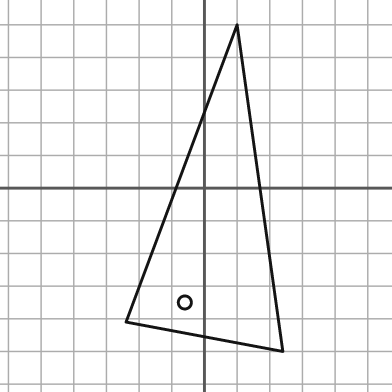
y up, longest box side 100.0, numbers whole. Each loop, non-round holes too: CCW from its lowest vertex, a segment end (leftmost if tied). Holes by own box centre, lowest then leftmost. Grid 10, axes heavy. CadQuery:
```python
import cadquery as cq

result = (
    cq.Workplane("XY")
    .moveTo(24.0, -50.0)
    .lineTo(10.0, 50.0)
    .lineTo(-24.0, -41.0)
    .close()
    .moveTo(-6.0, -35.0)
    .circle(2.0)
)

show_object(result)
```